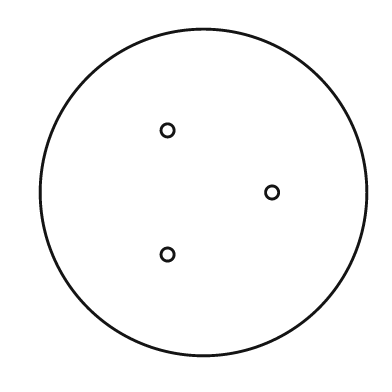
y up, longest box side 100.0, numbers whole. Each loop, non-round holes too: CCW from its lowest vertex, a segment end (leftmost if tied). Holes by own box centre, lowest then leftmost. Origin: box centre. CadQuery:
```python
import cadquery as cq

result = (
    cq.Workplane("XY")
    .moveTo(0.0, 0.0)
    .circle(50.0)
    .moveTo(-11.0, -19.0)
    .circle(2.0)
    .moveTo(21.0, 0.0)
    .circle(2.0)
    .moveTo(-11.0, 19.0)
    .circle(2.0)
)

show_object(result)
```